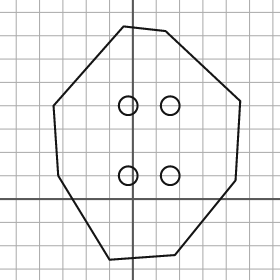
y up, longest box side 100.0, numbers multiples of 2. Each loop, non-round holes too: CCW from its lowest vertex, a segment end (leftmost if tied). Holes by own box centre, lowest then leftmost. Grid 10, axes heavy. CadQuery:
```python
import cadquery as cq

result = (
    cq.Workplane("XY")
    .moveTo(-10.0, -26.0)
    .lineTo(18.0, -24.0)
    .lineTo(44.0, 8.0)
    .lineTo(46.0, 42.0)
    .lineTo(14.0, 72.0)
    .lineTo(-4.0, 74.0)
    .lineTo(-34.0, 40.0)
    .lineTo(-32.0, 10.0)
    .close()
    .moveTo(-2.0, 10.0)
    .circle(4.0)
    .moveTo(16.0, 10.0)
    .circle(4.0)
    .moveTo(-2.0, 40.0)
    .circle(4.0)
    .moveTo(16.0, 40.0)
    .circle(4.0)
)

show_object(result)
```